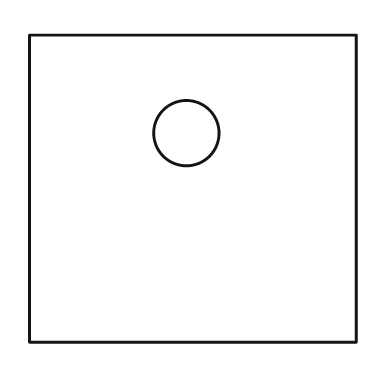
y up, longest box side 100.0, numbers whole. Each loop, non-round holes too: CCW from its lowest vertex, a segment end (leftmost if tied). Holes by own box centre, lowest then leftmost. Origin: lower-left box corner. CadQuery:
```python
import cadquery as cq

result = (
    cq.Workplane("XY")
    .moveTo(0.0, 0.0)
    .lineTo(100.0, 0.0)
    .lineTo(100.0, 94.0)
    .lineTo(0.0, 94.0)
    .close()
    .moveTo(48.0, 64.0)
    .circle(10.0)
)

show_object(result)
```